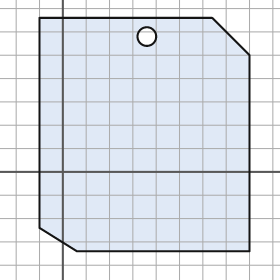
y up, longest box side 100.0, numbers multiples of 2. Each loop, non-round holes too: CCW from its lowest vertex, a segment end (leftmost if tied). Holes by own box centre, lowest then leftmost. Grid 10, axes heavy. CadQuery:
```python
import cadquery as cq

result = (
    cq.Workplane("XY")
    .moveTo(6.0, -34.0)
    .lineTo(80.0, -34.0)
    .lineTo(80.0, 50.0)
    .lineTo(64.0, 66.0)
    .lineTo(-10.0, 66.0)
    .lineTo(-10.0, -24.0)
    .close()
    .moveTo(36.0, 58.0)
    .circle(4.0)
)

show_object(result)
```